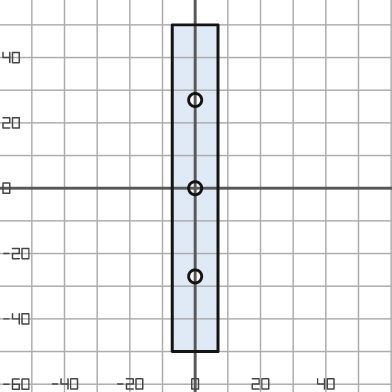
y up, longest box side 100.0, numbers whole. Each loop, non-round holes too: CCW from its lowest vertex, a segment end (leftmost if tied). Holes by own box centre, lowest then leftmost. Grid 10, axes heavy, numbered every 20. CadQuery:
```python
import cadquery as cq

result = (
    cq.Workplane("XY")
    .moveTo(-7.0, -50.0)
    .lineTo(7.0, -50.0)
    .lineTo(7.0, 50.0)
    .lineTo(-7.0, 50.0)
    .close()
    .moveTo(0.0, -27.0)
    .circle(2.0)
    .moveTo(0.0, 0.0)
    .circle(2.0)
    .moveTo(0.0, 27.0)
    .circle(2.0)
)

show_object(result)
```